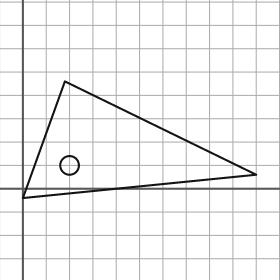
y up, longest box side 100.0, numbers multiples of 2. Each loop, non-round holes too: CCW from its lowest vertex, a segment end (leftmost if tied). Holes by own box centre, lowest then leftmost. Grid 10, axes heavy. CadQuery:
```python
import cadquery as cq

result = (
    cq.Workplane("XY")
    .moveTo(0.0, -4.0)
    .lineTo(100.0, 6.0)
    .lineTo(18.0, 46.0)
    .close()
    .moveTo(20.0, 10.0)
    .circle(4.0)
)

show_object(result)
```